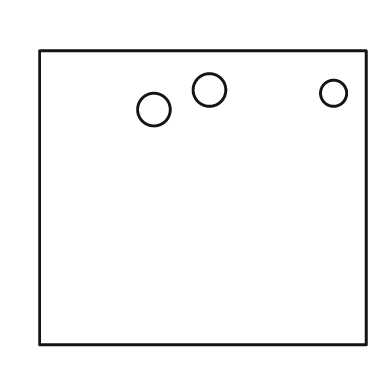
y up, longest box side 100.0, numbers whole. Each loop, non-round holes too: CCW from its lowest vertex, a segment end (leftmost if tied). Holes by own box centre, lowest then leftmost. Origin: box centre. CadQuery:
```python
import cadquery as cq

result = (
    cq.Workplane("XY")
    .moveTo(-50.0, -45.0)
    .lineTo(50.0, -45.0)
    .lineTo(50.0, 45.0)
    .lineTo(-50.0, 45.0)
    .close()
    .moveTo(-15.0, 27.0)
    .circle(5.0)
    .moveTo(40.0, 32.0)
    .circle(4.0)
    .moveTo(2.0, 33.0)
    .circle(5.0)
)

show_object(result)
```